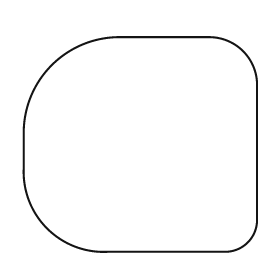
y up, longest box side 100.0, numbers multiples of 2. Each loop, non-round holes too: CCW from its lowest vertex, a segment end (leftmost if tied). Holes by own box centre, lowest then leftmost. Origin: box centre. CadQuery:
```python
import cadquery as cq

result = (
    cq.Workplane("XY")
    .moveTo(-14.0, -46.0)
    .lineTo(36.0, -46.0)
    .threePointArc((46.0, -42.0), (50.0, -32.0))
    .lineTo(50.0, 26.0)
    .threePointArc((44.0, 40.0), (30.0, 46.0))
    .lineTo(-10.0, 46.0)
    .threePointArc((-38.0, 34.0), (-50.0, 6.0))
    .lineTo(-50.0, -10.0)
    .threePointArc((-40.0, -36.0), (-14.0, -46.0))
    .close()
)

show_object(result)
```